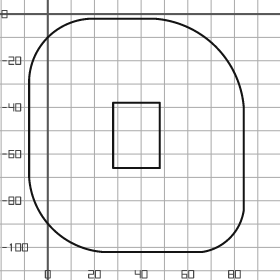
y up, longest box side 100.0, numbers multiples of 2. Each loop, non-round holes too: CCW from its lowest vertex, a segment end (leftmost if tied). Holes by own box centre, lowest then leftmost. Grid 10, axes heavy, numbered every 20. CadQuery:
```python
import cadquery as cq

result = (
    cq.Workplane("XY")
    .moveTo(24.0, -102.0)
    .lineTo(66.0, -102.0)
    .threePointArc((78.0, -96.0), (84.0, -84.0))
    .lineTo(84.0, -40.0)
    .threePointArc((72.0, -14.0), (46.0, -2.0))
    .lineTo(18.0, -2.0)
    .threePointArc((0.0, -10.0), (-8.0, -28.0))
    .lineTo(-8.0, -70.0)
    .threePointArc((2.0, -92.0), (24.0, -102.0))
    .close()
    .moveTo(28.0, -66.0)
    .lineTo(48.0, -66.0)
    .lineTo(48.0, -38.0)
    .lineTo(28.0, -38.0)
    .close()
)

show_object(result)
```